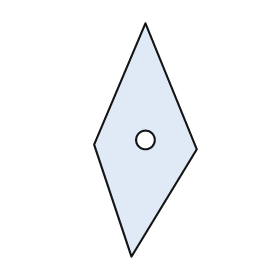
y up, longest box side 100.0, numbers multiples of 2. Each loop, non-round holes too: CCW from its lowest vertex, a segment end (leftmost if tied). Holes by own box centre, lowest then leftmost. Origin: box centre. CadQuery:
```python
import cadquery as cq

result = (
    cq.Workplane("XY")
    .moveTo(-6.0, -50.0)
    .lineTo(22.0, -4.0)
    .lineTo(0.0, 50.0)
    .lineTo(-22.0, -2.0)
    .close()
    .moveTo(0.0, 0.0)
    .circle(4.0)
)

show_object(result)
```